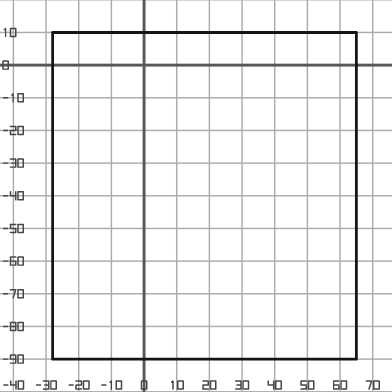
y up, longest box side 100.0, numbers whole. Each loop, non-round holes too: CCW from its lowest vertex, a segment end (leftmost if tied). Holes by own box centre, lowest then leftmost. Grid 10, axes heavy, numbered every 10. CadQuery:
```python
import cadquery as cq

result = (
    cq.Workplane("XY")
    .moveTo(-28.0, -90.0)
    .lineTo(65.0, -90.0)
    .lineTo(65.0, 10.0)
    .lineTo(-28.0, 10.0)
    .close()
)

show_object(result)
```